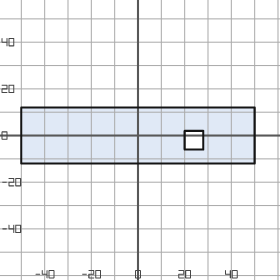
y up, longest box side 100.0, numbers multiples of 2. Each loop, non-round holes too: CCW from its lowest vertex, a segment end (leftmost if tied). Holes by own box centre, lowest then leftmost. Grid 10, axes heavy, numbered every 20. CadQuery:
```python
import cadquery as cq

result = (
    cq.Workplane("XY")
    .moveTo(-50.0, -12.0)
    .lineTo(50.0, -12.0)
    .lineTo(50.0, 12.0)
    .lineTo(-50.0, 12.0)
    .close()
    .moveTo(20.0, -6.0)
    .lineTo(28.0, -6.0)
    .lineTo(28.0, 2.0)
    .lineTo(20.0, 2.0)
    .close()
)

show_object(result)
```